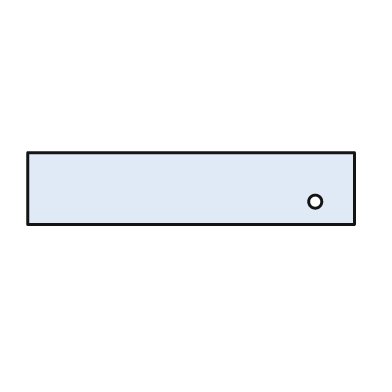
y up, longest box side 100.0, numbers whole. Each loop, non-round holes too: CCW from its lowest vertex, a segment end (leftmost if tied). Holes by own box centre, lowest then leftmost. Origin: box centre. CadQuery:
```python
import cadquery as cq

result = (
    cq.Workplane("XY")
    .moveTo(-50.0, -11.0)
    .lineTo(50.0, -11.0)
    .lineTo(50.0, 11.0)
    .lineTo(-50.0, 11.0)
    .close()
    .moveTo(38.0, -4.0)
    .circle(2.0)
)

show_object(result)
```